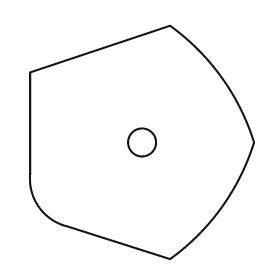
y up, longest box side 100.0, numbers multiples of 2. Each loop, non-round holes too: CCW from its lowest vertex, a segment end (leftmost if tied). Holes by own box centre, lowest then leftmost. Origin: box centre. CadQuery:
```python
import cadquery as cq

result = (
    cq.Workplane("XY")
    .moveTo(12.0, -50.0)
    .threePointArc((34.0, -28.0), (48.0, 0.0))
    .threePointArc((34.0, 28.0), (12.0, 50.0))
    .lineTo(-48.0, 30.0)
    .lineTo(-48.0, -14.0)
    .threePointArc((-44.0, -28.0), (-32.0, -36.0))
    .close()
    .moveTo(0.0, 0.0)
    .circle(6.0)
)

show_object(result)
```